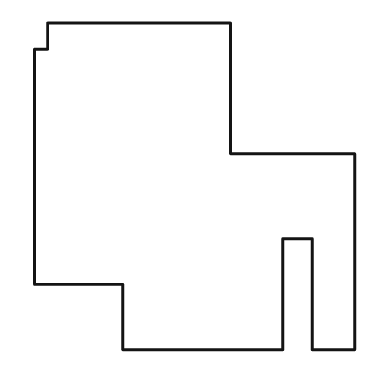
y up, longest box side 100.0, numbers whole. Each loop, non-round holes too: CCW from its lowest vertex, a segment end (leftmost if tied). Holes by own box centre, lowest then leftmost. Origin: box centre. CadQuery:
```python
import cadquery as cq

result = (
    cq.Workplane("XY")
    .moveTo(-22.0, -50.0)
    .lineTo(27.0, -50.0)
    .lineTo(27.0, -16.0)
    .lineTo(36.0, -16.0)
    .lineTo(36.0, -50.0)
    .lineTo(49.0, -50.0)
    .lineTo(49.0, 10.0)
    .lineTo(11.0, 10.0)
    .lineTo(11.0, 50.0)
    .lineTo(-45.0, 50.0)
    .lineTo(-45.0, 42.0)
    .lineTo(-49.0, 42.0)
    .lineTo(-49.0, -30.0)
    .lineTo(-22.0, -30.0)
    .close()
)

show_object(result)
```